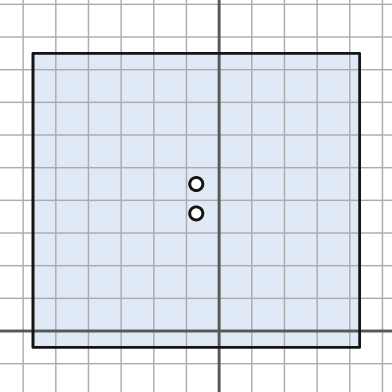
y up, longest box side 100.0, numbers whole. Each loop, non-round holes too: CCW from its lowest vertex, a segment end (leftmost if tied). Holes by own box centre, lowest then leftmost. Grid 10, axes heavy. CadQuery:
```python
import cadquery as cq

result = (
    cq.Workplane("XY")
    .moveTo(-57.0, -5.0)
    .lineTo(43.0, -5.0)
    .lineTo(43.0, 85.0)
    .lineTo(-57.0, 85.0)
    .close()
    .moveTo(-7.0, 36.0)
    .circle(2.0)
    .moveTo(-7.0, 45.0)
    .circle(2.0)
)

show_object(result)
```